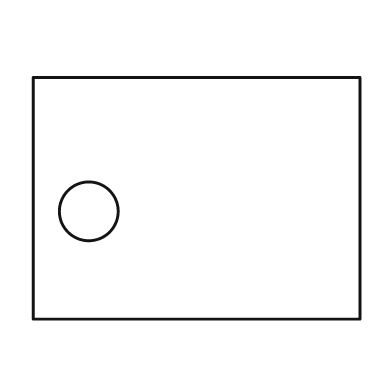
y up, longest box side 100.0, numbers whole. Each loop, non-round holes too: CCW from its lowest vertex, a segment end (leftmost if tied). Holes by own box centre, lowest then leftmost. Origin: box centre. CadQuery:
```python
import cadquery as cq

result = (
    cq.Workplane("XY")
    .moveTo(-50.0, -37.0)
    .lineTo(50.0, -37.0)
    .lineTo(50.0, 37.0)
    .lineTo(-50.0, 37.0)
    .close()
    .moveTo(-33.0, -4.0)
    .circle(9.0)
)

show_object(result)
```